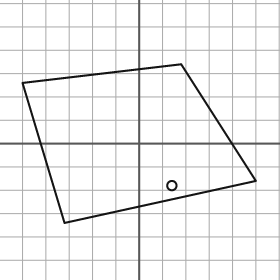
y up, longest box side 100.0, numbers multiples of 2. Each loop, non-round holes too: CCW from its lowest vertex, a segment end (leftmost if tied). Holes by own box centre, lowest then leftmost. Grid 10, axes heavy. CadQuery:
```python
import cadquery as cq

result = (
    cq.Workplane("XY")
    .moveTo(-32.0, -34.0)
    .lineTo(50.0, -16.0)
    .lineTo(18.0, 34.0)
    .lineTo(-50.0, 26.0)
    .close()
    .moveTo(14.0, -18.0)
    .circle(2.0)
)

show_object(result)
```